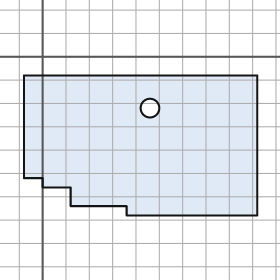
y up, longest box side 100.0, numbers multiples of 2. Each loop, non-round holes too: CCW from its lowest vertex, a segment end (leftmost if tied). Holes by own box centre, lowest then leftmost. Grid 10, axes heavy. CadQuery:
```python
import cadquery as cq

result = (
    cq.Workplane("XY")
    .moveTo(36.0, -68.0)
    .lineTo(92.0, -68.0)
    .lineTo(92.0, -8.0)
    .lineTo(-8.0, -8.0)
    .lineTo(-8.0, -52.0)
    .lineTo(0.0, -52.0)
    .lineTo(0.0, -56.0)
    .lineTo(12.0, -56.0)
    .lineTo(12.0, -64.0)
    .lineTo(36.0, -64.0)
    .close()
    .moveTo(46.0, -22.0)
    .circle(4.0)
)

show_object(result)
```